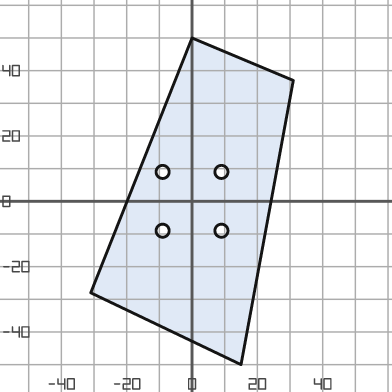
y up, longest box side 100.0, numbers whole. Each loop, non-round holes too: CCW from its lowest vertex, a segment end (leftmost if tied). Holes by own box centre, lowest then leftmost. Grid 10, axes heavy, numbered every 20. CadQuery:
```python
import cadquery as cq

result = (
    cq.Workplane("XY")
    .moveTo(15.0, -50.0)
    .lineTo(31.0, 37.0)
    .lineTo(0.0, 50.0)
    .lineTo(-31.0, -28.0)
    .close()
    .moveTo(-9.0, -9.0)
    .circle(2.0)
    .moveTo(9.0, -9.0)
    .circle(2.0)
    .moveTo(-9.0, 9.0)
    .circle(2.0)
    .moveTo(9.0, 9.0)
    .circle(2.0)
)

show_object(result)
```